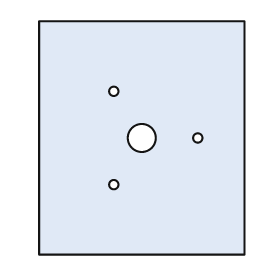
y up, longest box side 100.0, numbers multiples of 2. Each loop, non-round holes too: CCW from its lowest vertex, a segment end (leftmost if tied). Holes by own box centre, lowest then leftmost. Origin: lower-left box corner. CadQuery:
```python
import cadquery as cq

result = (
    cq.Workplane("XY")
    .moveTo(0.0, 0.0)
    .lineTo(88.0, 0.0)
    .lineTo(88.0, 100.0)
    .lineTo(0.0, 100.0)
    .close()
    .moveTo(32.0, 30.0)
    .circle(2.0)
    .moveTo(44.0, 50.0)
    .circle(6.0)
    .moveTo(68.0, 50.0)
    .circle(2.0)
    .moveTo(32.0, 70.0)
    .circle(2.0)
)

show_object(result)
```